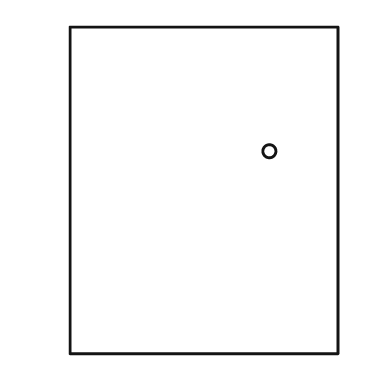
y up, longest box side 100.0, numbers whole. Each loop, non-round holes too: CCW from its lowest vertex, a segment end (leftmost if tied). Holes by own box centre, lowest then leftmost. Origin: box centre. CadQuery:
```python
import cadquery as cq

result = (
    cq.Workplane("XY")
    .moveTo(-41.0, -50.0)
    .lineTo(41.0, -50.0)
    .lineTo(41.0, 50.0)
    .lineTo(-41.0, 50.0)
    .close()
    .moveTo(20.0, 12.0)
    .circle(2.0)
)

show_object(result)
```